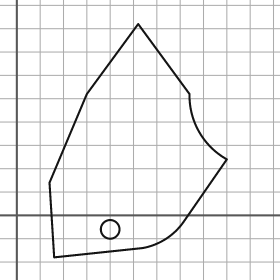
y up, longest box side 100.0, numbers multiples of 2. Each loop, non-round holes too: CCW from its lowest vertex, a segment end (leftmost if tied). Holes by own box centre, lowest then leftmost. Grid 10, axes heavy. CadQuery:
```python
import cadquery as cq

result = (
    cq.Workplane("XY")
    .moveTo(16.0, -18.0)
    .lineTo(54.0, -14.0)
    .threePointArc((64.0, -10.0), (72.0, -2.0))
    .lineTo(90.0, 24.0)
    .threePointArc((78.0, 36.0), (74.0, 52.0))
    .lineTo(52.0, 82.0)
    .lineTo(30.0, 52.0)
    .lineTo(14.0, 14.0)
    .close()
    .moveTo(40.0, -6.0)
    .circle(4.0)
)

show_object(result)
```